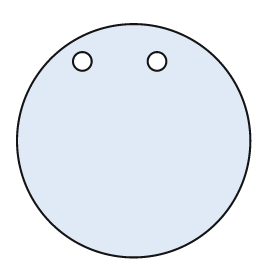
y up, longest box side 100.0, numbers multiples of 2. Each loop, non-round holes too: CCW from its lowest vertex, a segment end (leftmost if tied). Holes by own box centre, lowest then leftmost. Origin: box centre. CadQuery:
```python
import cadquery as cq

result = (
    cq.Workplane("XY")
    .moveTo(0.0, 0.0)
    .circle(50.0)
    .moveTo(-22.0, 34.0)
    .circle(4.0)
    .moveTo(10.0, 34.0)
    .circle(4.0)
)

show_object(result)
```